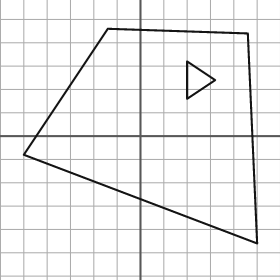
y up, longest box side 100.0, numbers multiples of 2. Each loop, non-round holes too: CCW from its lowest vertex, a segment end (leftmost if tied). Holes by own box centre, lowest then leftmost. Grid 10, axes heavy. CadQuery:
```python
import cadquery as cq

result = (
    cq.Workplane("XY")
    .moveTo(50.0, -46.0)
    .lineTo(46.0, 44.0)
    .lineTo(-14.0, 46.0)
    .lineTo(-50.0, -8.0)
    .close()
    .moveTo(20.0, 16.0)
    .lineTo(32.0, 24.0)
    .lineTo(20.0, 32.0)
    .close()
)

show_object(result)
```